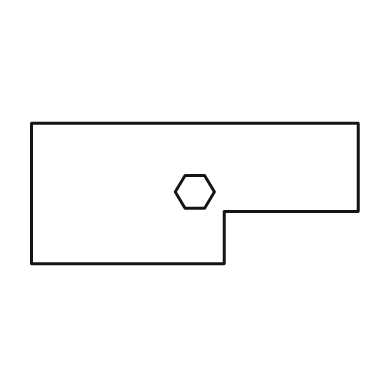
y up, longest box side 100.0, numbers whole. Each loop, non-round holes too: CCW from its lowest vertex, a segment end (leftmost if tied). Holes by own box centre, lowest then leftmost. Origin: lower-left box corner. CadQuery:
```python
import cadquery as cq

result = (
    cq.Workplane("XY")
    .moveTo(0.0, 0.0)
    .lineTo(59.0, 0.0)
    .lineTo(59.0, 16.0)
    .lineTo(100.0, 16.0)
    .lineTo(100.0, 43.0)
    .lineTo(0.0, 43.0)
    .close()
    .moveTo(47.0, 17.0)
    .lineTo(53.0, 17.0)
    .lineTo(56.0, 22.0)
    .lineTo(53.0, 27.0)
    .lineTo(47.0, 27.0)
    .lineTo(44.0, 22.0)
    .close()
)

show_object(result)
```